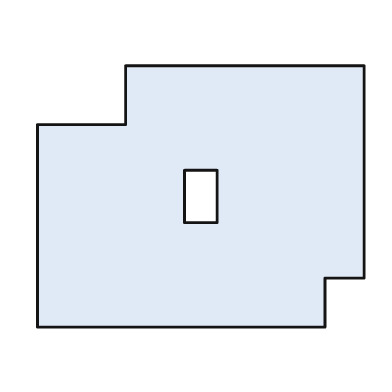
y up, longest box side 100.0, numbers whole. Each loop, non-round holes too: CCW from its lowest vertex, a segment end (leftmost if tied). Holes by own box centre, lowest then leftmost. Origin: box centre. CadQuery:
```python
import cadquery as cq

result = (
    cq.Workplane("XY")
    .moveTo(-50.0, -40.0)
    .lineTo(38.0, -40.0)
    .lineTo(38.0, -25.0)
    .lineTo(50.0, -25.0)
    .lineTo(50.0, 40.0)
    .lineTo(-23.0, 40.0)
    .lineTo(-23.0, 22.0)
    .lineTo(-50.0, 22.0)
    .close()
    .moveTo(-5.0, -8.0)
    .lineTo(5.0, -8.0)
    .lineTo(5.0, 8.0)
    .lineTo(-5.0, 8.0)
    .close()
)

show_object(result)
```